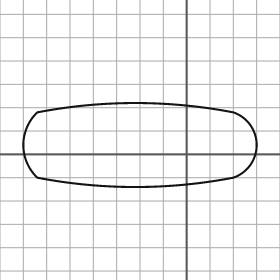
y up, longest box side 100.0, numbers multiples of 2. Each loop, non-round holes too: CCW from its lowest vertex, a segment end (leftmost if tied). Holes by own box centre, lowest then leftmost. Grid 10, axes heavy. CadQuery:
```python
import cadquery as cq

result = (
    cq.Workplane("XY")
    .moveTo(-64.0, -10.0)
    .threePointArc((-22.0, -14.0), (20.0, -10.0))
    .threePointArc((30.0, 4.0), (20.0, 18.0))
    .threePointArc((-22.0, 22.0), (-64.0, 18.0))
    .threePointArc((-70.0, 4.0), (-64.0, -10.0))
    .close()
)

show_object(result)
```